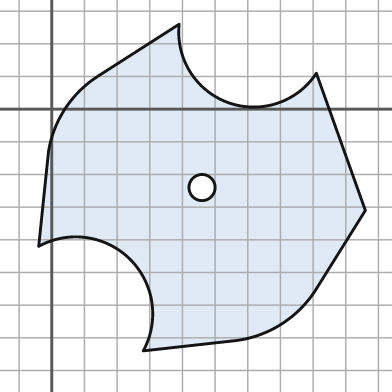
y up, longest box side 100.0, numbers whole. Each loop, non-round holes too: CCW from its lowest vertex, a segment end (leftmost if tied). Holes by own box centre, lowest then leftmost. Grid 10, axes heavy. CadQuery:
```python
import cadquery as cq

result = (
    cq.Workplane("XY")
    .moveTo(28.0, -74.0)
    .lineTo(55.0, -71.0)
    .threePointArc((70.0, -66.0), (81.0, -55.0))
    .lineTo(96.0, -31.0)
    .lineTo(81.0, 11.0)
    .threePointArc((54.0, 2.0), (39.0, 26.0))
    .lineTo(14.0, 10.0)
    .threePointArc((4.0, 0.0), (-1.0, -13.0))
    .lineTo(-4.0, -42.0)
    .threePointArc((24.0, -46.0), (28.0, -74.0))
    .close()
    .moveTo(46.0, -24.0)
    .circle(4.0)
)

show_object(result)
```